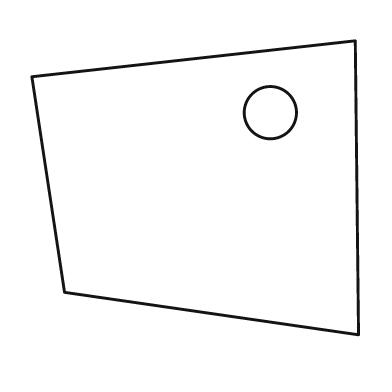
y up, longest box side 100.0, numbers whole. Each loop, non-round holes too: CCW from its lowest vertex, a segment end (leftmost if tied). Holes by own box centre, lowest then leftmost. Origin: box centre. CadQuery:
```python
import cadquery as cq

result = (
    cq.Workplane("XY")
    .moveTo(50.0, -45.0)
    .lineTo(49.0, 45.0)
    .lineTo(-50.0, 34.0)
    .lineTo(-40.0, -32.0)
    .close()
    .moveTo(23.0, 23.0)
    .circle(8.0)
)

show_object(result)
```